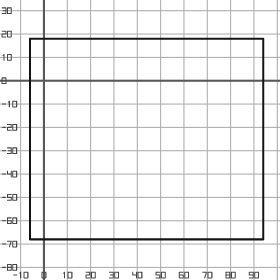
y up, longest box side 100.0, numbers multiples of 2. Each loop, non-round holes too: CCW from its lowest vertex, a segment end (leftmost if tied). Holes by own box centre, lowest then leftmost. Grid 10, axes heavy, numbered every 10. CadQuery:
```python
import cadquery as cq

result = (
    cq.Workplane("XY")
    .moveTo(-6.0, -68.0)
    .lineTo(94.0, -68.0)
    .lineTo(94.0, 18.0)
    .lineTo(-6.0, 18.0)
    .close()
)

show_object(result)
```